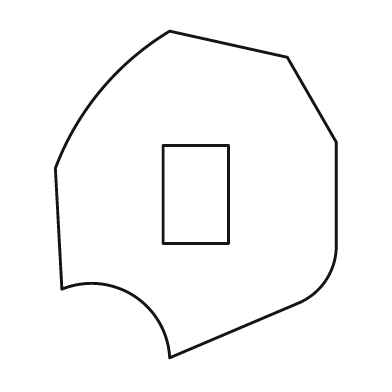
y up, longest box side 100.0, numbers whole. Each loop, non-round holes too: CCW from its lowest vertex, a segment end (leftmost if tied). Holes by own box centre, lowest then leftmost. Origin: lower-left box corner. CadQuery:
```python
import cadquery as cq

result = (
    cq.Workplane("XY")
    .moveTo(35.0, 0.0)
    .lineTo(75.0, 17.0)
    .threePointArc((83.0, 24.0), (86.0, 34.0))
    .lineTo(86.0, 66.0)
    .lineTo(71.0, 92.0)
    .lineTo(35.0, 100.0)
    .threePointArc((14.0, 82.0), (0.0, 58.0))
    .lineTo(2.0, 21.0)
    .threePointArc((24.0, 19.0), (35.0, 0.0))
    .close()
    .moveTo(33.0, 35.0)
    .lineTo(53.0, 35.0)
    .lineTo(53.0, 65.0)
    .lineTo(33.0, 65.0)
    .close()
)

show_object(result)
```